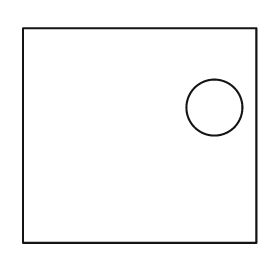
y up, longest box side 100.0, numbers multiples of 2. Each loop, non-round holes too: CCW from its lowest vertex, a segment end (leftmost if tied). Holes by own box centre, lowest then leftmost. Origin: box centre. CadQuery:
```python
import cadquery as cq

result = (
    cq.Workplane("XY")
    .moveTo(-50.0, -46.0)
    .lineTo(50.0, -46.0)
    .lineTo(50.0, 46.0)
    .lineTo(-50.0, 46.0)
    .close()
    .moveTo(32.0, 12.0)
    .circle(12.0)
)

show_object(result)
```